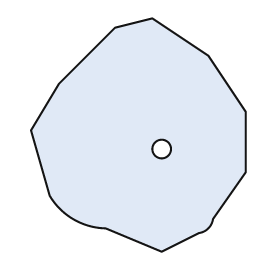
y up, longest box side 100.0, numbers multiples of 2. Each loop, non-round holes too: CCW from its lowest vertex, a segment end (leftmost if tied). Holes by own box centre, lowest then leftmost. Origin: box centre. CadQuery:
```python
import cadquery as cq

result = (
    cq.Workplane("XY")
    .moveTo(10.0, -50.0)
    .lineTo(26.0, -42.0)
    .threePointArc((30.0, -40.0), (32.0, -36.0))
    .lineTo(46.0, -16.0)
    .lineTo(46.0, 10.0)
    .lineTo(30.0, 34.0)
    .lineTo(6.0, 50.0)
    .lineTo(-10.0, 46.0)
    .lineTo(-34.0, 22.0)
    .lineTo(-46.0, 2.0)
    .lineTo(-38.0, -26.0)
    .threePointArc((-28.0, -36.0), (-14.0, -40.0))
    .close()
    .moveTo(10.0, -6.0)
    .circle(4.0)
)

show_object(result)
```